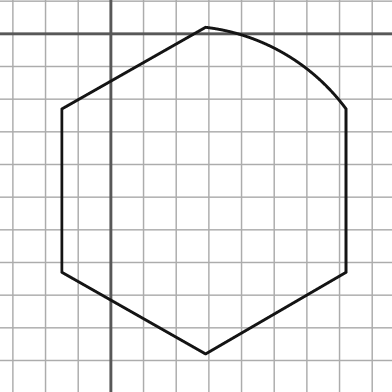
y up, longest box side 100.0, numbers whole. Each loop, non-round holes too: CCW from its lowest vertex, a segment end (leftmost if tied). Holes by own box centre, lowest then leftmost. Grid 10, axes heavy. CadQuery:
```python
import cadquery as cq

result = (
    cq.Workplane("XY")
    .moveTo(29.0, -98.0)
    .lineTo(72.0, -73.0)
    .lineTo(72.0, -23.0)
    .threePointArc((53.0, -6.0), (29.0, 2.0))
    .lineTo(-15.0, -23.0)
    .lineTo(-15.0, -73.0)
    .close()
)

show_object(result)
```